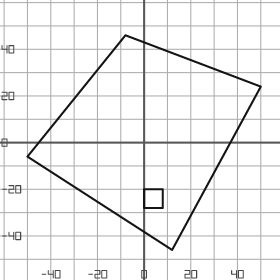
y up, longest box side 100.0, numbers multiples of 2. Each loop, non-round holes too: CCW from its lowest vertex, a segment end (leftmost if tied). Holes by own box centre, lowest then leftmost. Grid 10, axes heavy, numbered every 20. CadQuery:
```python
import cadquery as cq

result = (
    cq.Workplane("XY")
    .moveTo(12.0, -46.0)
    .lineTo(50.0, 24.0)
    .lineTo(-8.0, 46.0)
    .lineTo(-50.0, -6.0)
    .close()
    .moveTo(0.0, -28.0)
    .lineTo(8.0, -28.0)
    .lineTo(8.0, -20.0)
    .lineTo(0.0, -20.0)
    .close()
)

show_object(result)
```